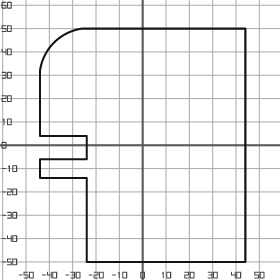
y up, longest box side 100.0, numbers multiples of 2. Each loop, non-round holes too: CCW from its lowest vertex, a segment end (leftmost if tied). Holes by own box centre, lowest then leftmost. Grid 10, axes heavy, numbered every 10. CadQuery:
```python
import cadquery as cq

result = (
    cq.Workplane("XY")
    .moveTo(-24.0, -50.0)
    .lineTo(44.0, -50.0)
    .lineTo(44.0, 50.0)
    .lineTo(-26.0, 50.0)
    .threePointArc((-38.0, 44.0), (-44.0, 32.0))
    .lineTo(-44.0, 4.0)
    .lineTo(-24.0, 4.0)
    .lineTo(-24.0, -6.0)
    .lineTo(-44.0, -6.0)
    .lineTo(-44.0, -14.0)
    .lineTo(-24.0, -14.0)
    .close()
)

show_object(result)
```